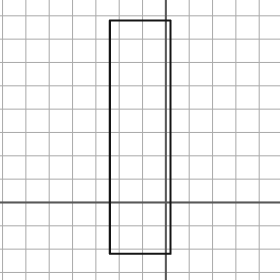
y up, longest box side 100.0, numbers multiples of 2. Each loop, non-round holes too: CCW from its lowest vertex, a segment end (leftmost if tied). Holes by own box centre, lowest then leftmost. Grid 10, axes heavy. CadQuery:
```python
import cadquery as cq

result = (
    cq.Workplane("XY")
    .moveTo(-24.0, -22.0)
    .lineTo(2.0, -22.0)
    .lineTo(2.0, 78.0)
    .lineTo(-24.0, 78.0)
    .close()
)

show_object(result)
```